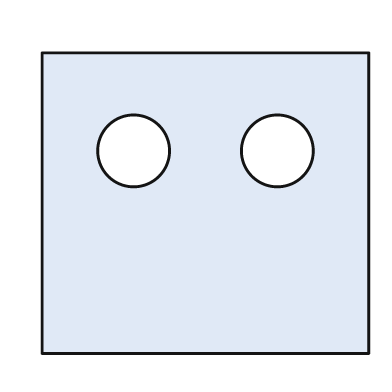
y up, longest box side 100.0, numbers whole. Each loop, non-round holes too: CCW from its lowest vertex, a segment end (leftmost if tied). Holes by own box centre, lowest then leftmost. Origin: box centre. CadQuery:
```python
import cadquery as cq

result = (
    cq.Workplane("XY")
    .moveTo(-50.0, -46.0)
    .lineTo(50.0, -46.0)
    .lineTo(50.0, 46.0)
    .lineTo(-50.0, 46.0)
    .close()
    .moveTo(-22.0, 16.0)
    .circle(11.0)
    .moveTo(22.0, 16.0)
    .circle(11.0)
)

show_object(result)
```